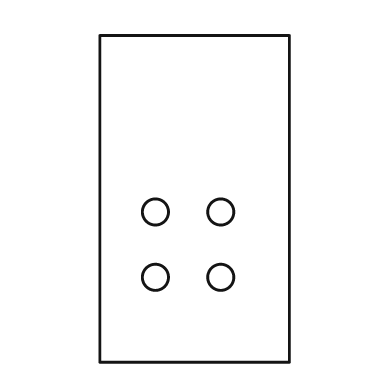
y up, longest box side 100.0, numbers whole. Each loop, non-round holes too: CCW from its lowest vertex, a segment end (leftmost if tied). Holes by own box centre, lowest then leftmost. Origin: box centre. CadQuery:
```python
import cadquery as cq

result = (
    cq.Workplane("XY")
    .moveTo(-29.0, -50.0)
    .lineTo(29.0, -50.0)
    .lineTo(29.0, 50.0)
    .lineTo(-29.0, 50.0)
    .close()
    .moveTo(-12.0, -24.0)
    .circle(4.0)
    .moveTo(8.0, -24.0)
    .circle(4.0)
    .moveTo(-12.0, -4.0)
    .circle(4.0)
    .moveTo(8.0, -4.0)
    .circle(4.0)
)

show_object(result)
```